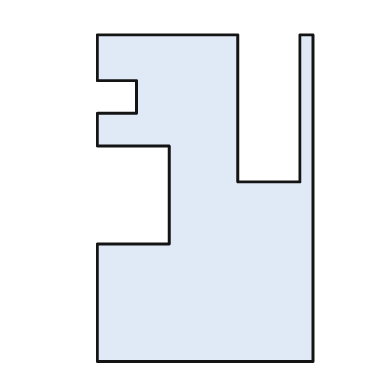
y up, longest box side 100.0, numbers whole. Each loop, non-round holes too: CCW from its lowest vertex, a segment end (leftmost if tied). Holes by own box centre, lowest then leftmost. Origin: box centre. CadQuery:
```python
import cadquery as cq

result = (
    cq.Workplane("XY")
    .moveTo(-33.0, -50.0)
    .lineTo(33.0, -50.0)
    .lineTo(33.0, 50.0)
    .lineTo(29.0, 50.0)
    .lineTo(29.0, 5.0)
    .lineTo(10.0, 5.0)
    .lineTo(10.0, 50.0)
    .lineTo(-33.0, 50.0)
    .lineTo(-33.0, 36.0)
    .lineTo(-21.0, 36.0)
    .lineTo(-21.0, 26.0)
    .lineTo(-33.0, 26.0)
    .lineTo(-33.0, 16.0)
    .lineTo(-11.0, 16.0)
    .lineTo(-11.0, -14.0)
    .lineTo(-33.0, -14.0)
    .close()
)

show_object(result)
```